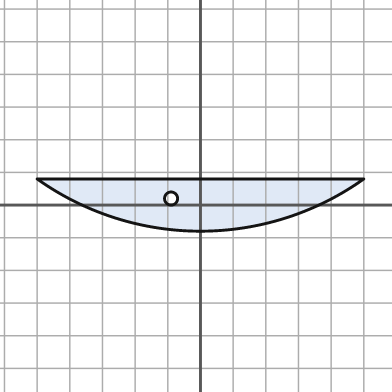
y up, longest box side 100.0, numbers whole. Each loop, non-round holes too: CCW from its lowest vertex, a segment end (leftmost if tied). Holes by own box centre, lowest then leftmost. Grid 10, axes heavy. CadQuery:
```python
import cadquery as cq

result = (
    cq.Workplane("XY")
    .moveTo(-50.0, 8.0)
    .threePointArc((0.0, -8.0), (50.0, 8.0))
    .close()
    .moveTo(-9.0, 2.0)
    .circle(2.0)
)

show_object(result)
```